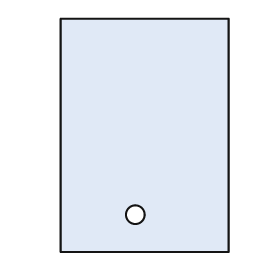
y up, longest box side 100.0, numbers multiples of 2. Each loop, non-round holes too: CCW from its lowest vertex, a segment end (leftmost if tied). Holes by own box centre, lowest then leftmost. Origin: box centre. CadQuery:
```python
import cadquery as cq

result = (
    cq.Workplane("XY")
    .moveTo(-36.0, -50.0)
    .lineTo(36.0, -50.0)
    .lineTo(36.0, 50.0)
    .lineTo(-36.0, 50.0)
    .close()
    .moveTo(-4.0, -34.0)
    .circle(4.0)
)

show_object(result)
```